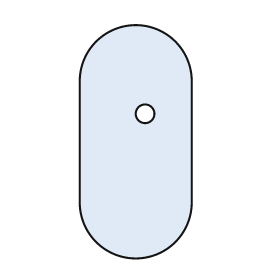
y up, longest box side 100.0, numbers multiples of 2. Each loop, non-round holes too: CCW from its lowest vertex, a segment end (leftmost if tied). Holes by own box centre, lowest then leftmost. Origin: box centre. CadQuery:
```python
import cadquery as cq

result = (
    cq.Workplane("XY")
    .moveTo(-24.0, -26.0)
    .threePointArc((0.0, -50.0), (24.0, -26.0))
    .lineTo(24.0, 26.0)
    .threePointArc((0.0, 50.0), (-24.0, 26.0))
    .close()
    .moveTo(4.0, 12.0)
    .circle(4.0)
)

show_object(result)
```